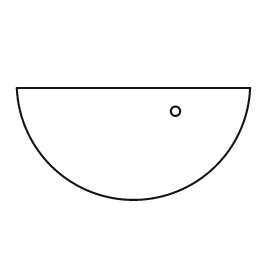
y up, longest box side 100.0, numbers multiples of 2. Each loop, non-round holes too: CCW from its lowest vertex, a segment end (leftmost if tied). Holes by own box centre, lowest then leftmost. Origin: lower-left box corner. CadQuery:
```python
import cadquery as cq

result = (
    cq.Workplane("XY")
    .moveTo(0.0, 48.0)
    .threePointArc((50.0, 0.0), (100.0, 48.0))
    .close()
    .moveTo(68.0, 38.0)
    .circle(2.0)
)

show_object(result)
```